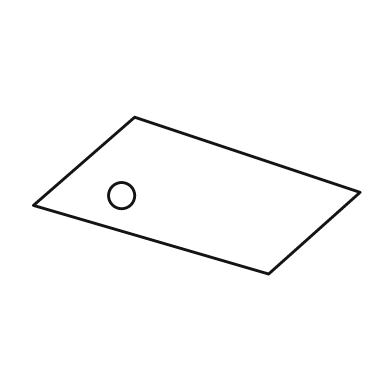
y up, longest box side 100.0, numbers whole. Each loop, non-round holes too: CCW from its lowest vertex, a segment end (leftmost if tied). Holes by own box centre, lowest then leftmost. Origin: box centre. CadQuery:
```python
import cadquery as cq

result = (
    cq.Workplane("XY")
    .moveTo(22.0, -24.0)
    .lineTo(50.0, 1.0)
    .lineTo(-19.0, 24.0)
    .lineTo(-50.0, -3.0)
    .close()
    .moveTo(-23.0, 0.0)
    .circle(4.0)
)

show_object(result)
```